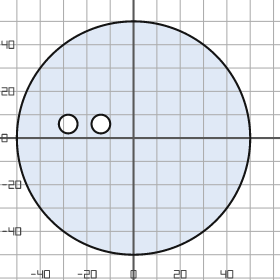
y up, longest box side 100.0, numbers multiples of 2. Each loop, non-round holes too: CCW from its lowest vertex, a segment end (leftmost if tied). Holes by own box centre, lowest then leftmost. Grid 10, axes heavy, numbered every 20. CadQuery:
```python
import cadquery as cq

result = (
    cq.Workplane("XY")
    .moveTo(0.0, 0.0)
    .circle(50.0)
    .moveTo(-28.0, 6.0)
    .circle(4.0)
    .moveTo(-14.0, 6.0)
    .circle(4.0)
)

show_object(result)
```